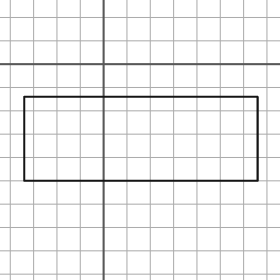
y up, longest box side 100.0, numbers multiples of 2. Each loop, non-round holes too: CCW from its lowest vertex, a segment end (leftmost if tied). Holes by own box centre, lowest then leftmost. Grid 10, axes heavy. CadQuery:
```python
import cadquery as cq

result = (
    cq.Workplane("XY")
    .moveTo(-34.0, -50.0)
    .lineTo(66.0, -50.0)
    .lineTo(66.0, -14.0)
    .lineTo(-34.0, -14.0)
    .close()
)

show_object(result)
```